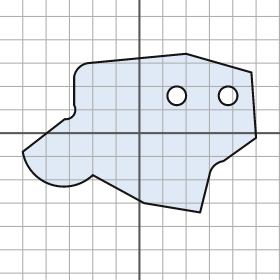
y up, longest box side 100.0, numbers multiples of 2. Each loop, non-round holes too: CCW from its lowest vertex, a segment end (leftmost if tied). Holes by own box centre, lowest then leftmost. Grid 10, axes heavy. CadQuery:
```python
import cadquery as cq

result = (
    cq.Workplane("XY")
    .moveTo(26.0, -34.0)
    .lineTo(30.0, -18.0)
    .threePointArc((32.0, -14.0), (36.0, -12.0))
    .lineTo(50.0, -2.0)
    .lineTo(48.0, 26.0)
    .lineTo(20.0, 34.0)
    .lineTo(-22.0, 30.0)
    .threePointArc((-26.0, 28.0), (-28.0, 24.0))
    .lineTo(-28.0, 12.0)
    .threePointArc((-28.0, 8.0), (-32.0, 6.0))
    .lineTo(-50.0, -8.0)
    .threePointArc((-38.0, -22.0), (-20.0, -18.0))
    .lineTo(2.0, -30.0)
    .close()
    .moveTo(16.0, 16.0)
    .circle(4.0)
    .moveTo(38.0, 16.0)
    .circle(4.0)
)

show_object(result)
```